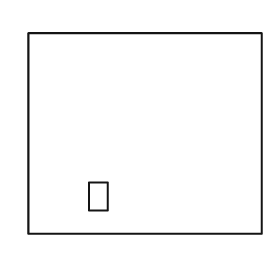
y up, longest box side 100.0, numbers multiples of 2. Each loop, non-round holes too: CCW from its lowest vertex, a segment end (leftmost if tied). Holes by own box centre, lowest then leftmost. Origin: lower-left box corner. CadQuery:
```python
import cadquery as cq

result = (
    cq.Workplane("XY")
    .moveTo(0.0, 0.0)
    .lineTo(100.0, 0.0)
    .lineTo(100.0, 86.0)
    .lineTo(0.0, 86.0)
    .close()
    .moveTo(26.0, 10.0)
    .lineTo(34.0, 10.0)
    .lineTo(34.0, 22.0)
    .lineTo(26.0, 22.0)
    .close()
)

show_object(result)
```